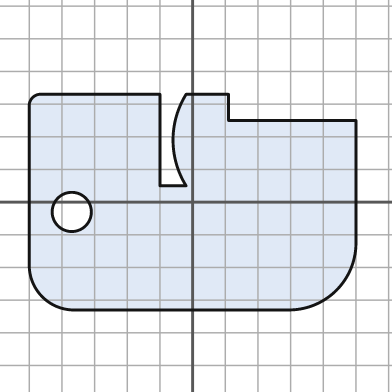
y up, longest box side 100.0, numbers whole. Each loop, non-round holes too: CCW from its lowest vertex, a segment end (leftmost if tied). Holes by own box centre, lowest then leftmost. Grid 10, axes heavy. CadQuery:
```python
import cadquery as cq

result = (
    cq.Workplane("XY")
    .moveTo(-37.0, -33.0)
    .lineTo(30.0, -33.0)
    .threePointArc((44.0, -27.0), (50.0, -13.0))
    .lineTo(50.0, 25.0)
    .lineTo(11.0, 25.0)
    .lineTo(11.0, 33.0)
    .lineTo(-2.0, 33.0)
    .threePointArc((-6.0, 19.0), (-2.0, 5.0))
    .lineTo(-10.0, 5.0)
    .lineTo(-10.0, 33.0)
    .lineTo(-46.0, 33.0)
    .threePointArc((-49.0, 32.0), (-50.0, 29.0))
    .lineTo(-50.0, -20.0)
    .threePointArc((-46.0, -29.0), (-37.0, -33.0))
    .close()
    .moveTo(-37.0, -3.0)
    .circle(6.0)
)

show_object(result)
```